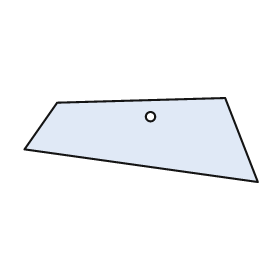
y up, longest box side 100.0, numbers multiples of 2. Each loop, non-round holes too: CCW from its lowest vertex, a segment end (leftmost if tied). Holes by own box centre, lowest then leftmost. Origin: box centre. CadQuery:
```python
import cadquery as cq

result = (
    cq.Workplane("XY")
    .moveTo(50.0, -18.0)
    .lineTo(36.0, 18.0)
    .lineTo(-36.0, 16.0)
    .lineTo(-50.0, -4.0)
    .close()
    .moveTo(4.0, 10.0)
    .circle(2.0)
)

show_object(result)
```